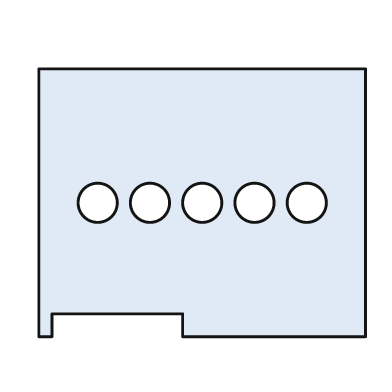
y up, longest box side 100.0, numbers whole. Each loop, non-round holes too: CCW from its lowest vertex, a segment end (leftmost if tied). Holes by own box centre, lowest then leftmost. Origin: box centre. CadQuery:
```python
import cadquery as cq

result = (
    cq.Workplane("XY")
    .moveTo(-50.0, -41.0)
    .lineTo(-46.0, -41.0)
    .lineTo(-46.0, -34.0)
    .lineTo(-6.0, -34.0)
    .lineTo(-6.0, -41.0)
    .lineTo(50.0, -41.0)
    .lineTo(50.0, 41.0)
    .lineTo(-50.0, 41.0)
    .close()
    .moveTo(-32.0, 0.0)
    .circle(6.0)
    .moveTo(-16.0, 0.0)
    .circle(6.0)
    .moveTo(0.0, 0.0)
    .circle(6.0)
    .moveTo(16.0, 0.0)
    .circle(6.0)
    .moveTo(32.0, 0.0)
    .circle(6.0)
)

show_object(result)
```